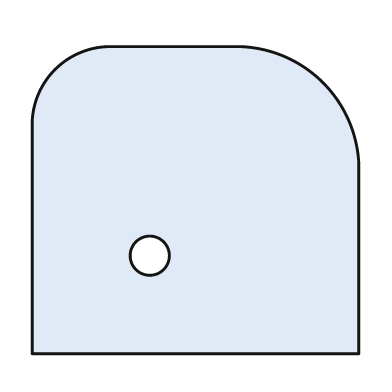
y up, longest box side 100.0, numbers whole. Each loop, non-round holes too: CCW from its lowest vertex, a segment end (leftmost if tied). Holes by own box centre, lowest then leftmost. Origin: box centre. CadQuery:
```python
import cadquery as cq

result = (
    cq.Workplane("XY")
    .moveTo(-50.0, -47.0)
    .lineTo(50.0, -47.0)
    .lineTo(50.0, 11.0)
    .threePointArc((39.0, 36.0), (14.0, 47.0))
    .lineTo(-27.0, 47.0)
    .threePointArc((-43.0, 40.0), (-50.0, 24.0))
    .close()
    .moveTo(-14.0, -17.0)
    .circle(6.0)
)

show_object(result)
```